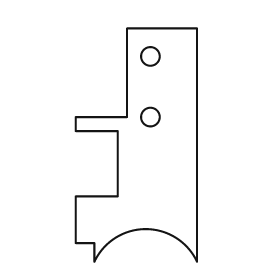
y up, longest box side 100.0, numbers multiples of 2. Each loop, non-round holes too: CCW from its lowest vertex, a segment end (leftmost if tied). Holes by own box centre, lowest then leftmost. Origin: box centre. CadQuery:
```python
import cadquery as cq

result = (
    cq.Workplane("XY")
    .moveTo(-18.0, -50.0)
    .threePointArc((4.0, -36.0), (26.0, -50.0))
    .lineTo(26.0, 50.0)
    .lineTo(-4.0, 50.0)
    .lineTo(-4.0, 12.0)
    .lineTo(-26.0, 12.0)
    .lineTo(-26.0, 6.0)
    .lineTo(-8.0, 6.0)
    .lineTo(-8.0, -22.0)
    .lineTo(-26.0, -22.0)
    .lineTo(-26.0, -42.0)
    .lineTo(-18.0, -42.0)
    .close()
    .moveTo(6.0, 12.0)
    .circle(4.0)
    .moveTo(6.0, 38.0)
    .circle(4.0)
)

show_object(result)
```